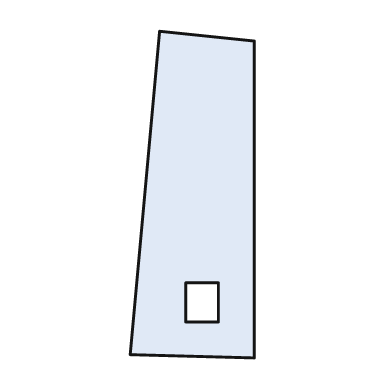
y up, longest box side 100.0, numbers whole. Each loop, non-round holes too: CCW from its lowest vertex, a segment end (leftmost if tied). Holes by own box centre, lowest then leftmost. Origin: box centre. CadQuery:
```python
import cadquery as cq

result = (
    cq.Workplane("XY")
    .moveTo(19.0, -50.0)
    .lineTo(19.0, 47.0)
    .lineTo(-10.0, 50.0)
    .lineTo(-19.0, -49.0)
    .close()
    .moveTo(-2.0, -39.0)
    .lineTo(8.0, -39.0)
    .lineTo(8.0, -27.0)
    .lineTo(-2.0, -27.0)
    .close()
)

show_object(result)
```